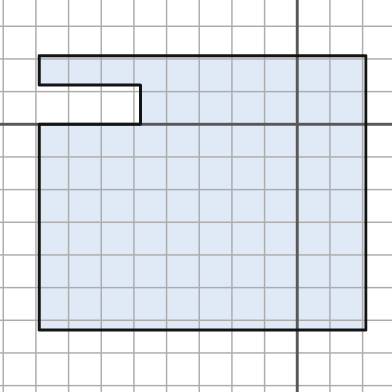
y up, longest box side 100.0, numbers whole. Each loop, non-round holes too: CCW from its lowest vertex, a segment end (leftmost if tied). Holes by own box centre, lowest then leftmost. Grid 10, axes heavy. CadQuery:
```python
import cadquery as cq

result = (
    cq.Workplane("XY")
    .moveTo(-79.0, -63.0)
    .lineTo(21.0, -63.0)
    .lineTo(21.0, 21.0)
    .lineTo(-79.0, 21.0)
    .lineTo(-79.0, 12.0)
    .lineTo(-48.0, 12.0)
    .lineTo(-48.0, 0.0)
    .lineTo(-79.0, 0.0)
    .close()
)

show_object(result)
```